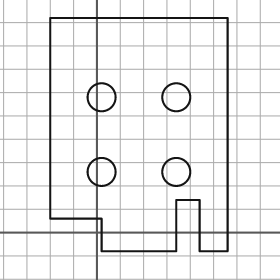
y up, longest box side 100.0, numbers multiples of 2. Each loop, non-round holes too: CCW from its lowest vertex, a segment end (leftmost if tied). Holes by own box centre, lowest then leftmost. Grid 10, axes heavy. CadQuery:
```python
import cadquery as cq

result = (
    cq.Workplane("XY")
    .moveTo(2.0, -8.0)
    .lineTo(34.0, -8.0)
    .lineTo(34.0, 14.0)
    .lineTo(44.0, 14.0)
    .lineTo(44.0, -8.0)
    .lineTo(56.0, -8.0)
    .lineTo(56.0, 92.0)
    .lineTo(-20.0, 92.0)
    .lineTo(-20.0, 6.0)
    .lineTo(2.0, 6.0)
    .close()
    .moveTo(2.0, 26.0)
    .circle(6.0)
    .moveTo(34.0, 26.0)
    .circle(6.0)
    .moveTo(2.0, 58.0)
    .circle(6.0)
    .moveTo(34.0, 58.0)
    .circle(6.0)
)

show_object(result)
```